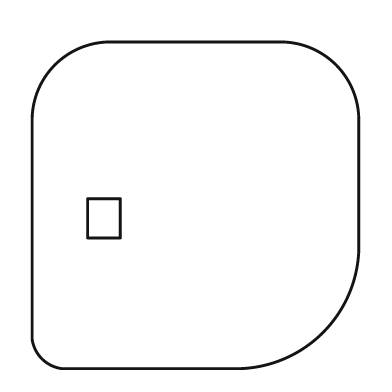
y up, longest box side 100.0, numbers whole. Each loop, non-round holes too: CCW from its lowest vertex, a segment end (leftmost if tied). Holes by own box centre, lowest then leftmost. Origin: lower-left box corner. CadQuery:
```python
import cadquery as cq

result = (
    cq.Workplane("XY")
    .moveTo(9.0, 0.0)
    .lineTo(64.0, 0.0)
    .threePointArc((89.0, 11.0), (100.0, 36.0))
    .lineTo(100.0, 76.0)
    .threePointArc((93.0, 93.0), (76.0, 100.0))
    .lineTo(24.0, 100.0)
    .threePointArc((7.0, 93.0), (0.0, 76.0))
    .lineTo(0.0, 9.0)
    .threePointArc((3.0, 3.0), (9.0, 0.0))
    .close()
    .moveTo(17.0, 40.0)
    .lineTo(27.0, 40.0)
    .lineTo(27.0, 52.0)
    .lineTo(17.0, 52.0)
    .close()
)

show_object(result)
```